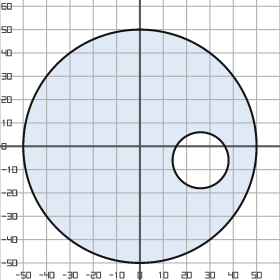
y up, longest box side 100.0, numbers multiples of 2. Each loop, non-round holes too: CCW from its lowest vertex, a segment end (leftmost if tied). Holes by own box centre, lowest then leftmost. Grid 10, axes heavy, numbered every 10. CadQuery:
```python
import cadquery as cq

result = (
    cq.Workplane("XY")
    .moveTo(0.0, 0.0)
    .circle(50.0)
    .moveTo(26.0, -6.0)
    .circle(12.0)
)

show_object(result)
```